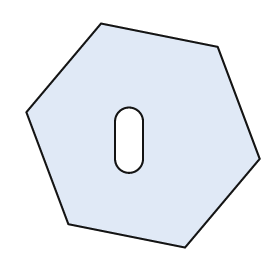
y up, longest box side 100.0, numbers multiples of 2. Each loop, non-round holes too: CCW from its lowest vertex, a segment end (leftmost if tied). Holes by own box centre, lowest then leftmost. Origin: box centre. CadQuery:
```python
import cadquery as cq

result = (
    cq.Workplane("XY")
    .moveTo(18.0, -48.0)
    .lineTo(50.0, -10.0)
    .lineTo(32.0, 38.0)
    .lineTo(-18.0, 48.0)
    .lineTo(-50.0, 10.0)
    .lineTo(-32.0, -38.0)
    .close()
    .moveTo(-12.0, -10.0)
    .threePointArc((-6.0, -16.0), (0.0, -10.0))
    .lineTo(0.0, 6.0)
    .threePointArc((-6.0, 12.0), (-12.0, 6.0))
    .close()
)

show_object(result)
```